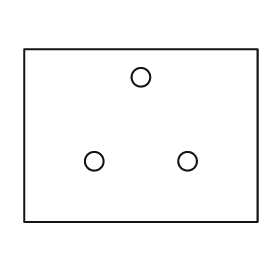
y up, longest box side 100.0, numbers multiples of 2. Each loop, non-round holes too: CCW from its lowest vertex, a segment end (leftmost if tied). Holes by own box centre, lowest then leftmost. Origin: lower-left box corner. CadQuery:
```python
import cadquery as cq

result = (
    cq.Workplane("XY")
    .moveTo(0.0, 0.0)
    .lineTo(100.0, 0.0)
    .lineTo(100.0, 74.0)
    .lineTo(0.0, 74.0)
    .close()
    .moveTo(30.0, 26.0)
    .circle(4.0)
    .moveTo(70.0, 26.0)
    .circle(4.0)
    .moveTo(50.0, 62.0)
    .circle(4.0)
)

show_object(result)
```